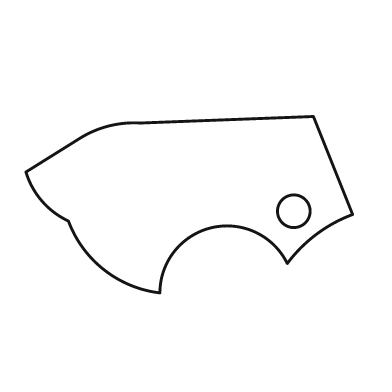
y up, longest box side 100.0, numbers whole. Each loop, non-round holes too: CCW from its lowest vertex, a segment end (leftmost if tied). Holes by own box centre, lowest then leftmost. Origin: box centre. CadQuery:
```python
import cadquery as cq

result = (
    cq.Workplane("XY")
    .moveTo(-9.0, -27.0)
    .threePointArc((7.0, -7.0), (30.0, -18.0))
    .threePointArc((39.0, -9.0), (50.0, -3.0))
    .lineTo(38.0, 27.0)
    .lineTo(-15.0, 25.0)
    .threePointArc((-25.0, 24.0), (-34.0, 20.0))
    .lineTo(-50.0, 10.0)
    .threePointArc((-45.0, 1.0), (-37.0, -5.0))
    .threePointArc((-26.0, -20.0), (-9.0, -27.0))
    .close()
    .moveTo(32.0, -2.0)
    .circle(5.0)
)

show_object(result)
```